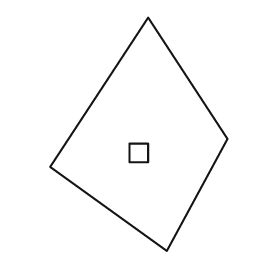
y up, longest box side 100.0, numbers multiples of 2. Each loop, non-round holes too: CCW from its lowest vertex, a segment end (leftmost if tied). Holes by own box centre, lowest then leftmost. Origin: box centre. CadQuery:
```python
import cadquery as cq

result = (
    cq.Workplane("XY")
    .moveTo(12.0, -50.0)
    .lineTo(38.0, -2.0)
    .lineTo(4.0, 50.0)
    .lineTo(-38.0, -14.0)
    .close()
    .moveTo(-4.0, -12.0)
    .lineTo(4.0, -12.0)
    .lineTo(4.0, -4.0)
    .lineTo(-4.0, -4.0)
    .close()
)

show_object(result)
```